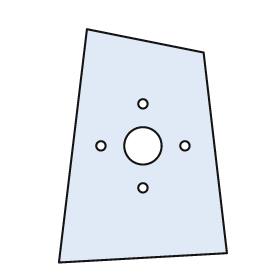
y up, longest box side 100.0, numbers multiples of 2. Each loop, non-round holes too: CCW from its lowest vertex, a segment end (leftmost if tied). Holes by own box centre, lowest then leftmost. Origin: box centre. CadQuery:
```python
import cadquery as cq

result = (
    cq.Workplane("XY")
    .moveTo(-36.0, -50.0)
    .lineTo(36.0, -46.0)
    .lineTo(26.0, 40.0)
    .lineTo(-24.0, 50.0)
    .close()
    .moveTo(0.0, -18.0)
    .circle(2.0)
    .moveTo(-18.0, 0.0)
    .circle(2.0)
    .moveTo(0.0, 0.0)
    .circle(8.0)
    .moveTo(18.0, 0.0)
    .circle(2.0)
    .moveTo(0.0, 18.0)
    .circle(2.0)
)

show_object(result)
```